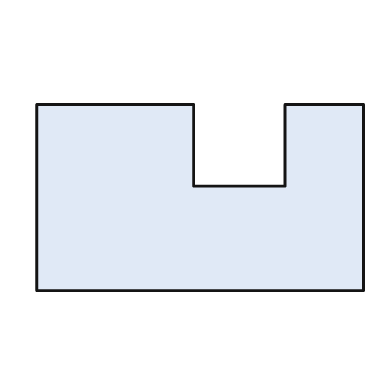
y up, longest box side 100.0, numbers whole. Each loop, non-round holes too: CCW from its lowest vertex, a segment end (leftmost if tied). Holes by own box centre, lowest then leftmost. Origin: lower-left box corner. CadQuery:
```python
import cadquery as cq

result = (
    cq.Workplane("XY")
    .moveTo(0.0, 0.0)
    .lineTo(100.0, 0.0)
    .lineTo(100.0, 57.0)
    .lineTo(76.0, 57.0)
    .lineTo(76.0, 32.0)
    .lineTo(48.0, 32.0)
    .lineTo(48.0, 57.0)
    .lineTo(0.0, 57.0)
    .close()
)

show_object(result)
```